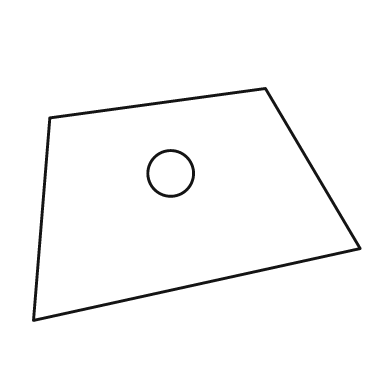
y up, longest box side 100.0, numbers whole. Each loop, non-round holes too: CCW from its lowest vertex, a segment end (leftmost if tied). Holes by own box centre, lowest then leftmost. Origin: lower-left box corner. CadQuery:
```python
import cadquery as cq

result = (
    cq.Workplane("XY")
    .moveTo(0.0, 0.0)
    .lineTo(100.0, 22.0)
    .lineTo(71.0, 71.0)
    .lineTo(5.0, 62.0)
    .close()
    .moveTo(42.0, 45.0)
    .circle(7.0)
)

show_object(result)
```